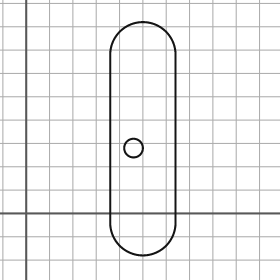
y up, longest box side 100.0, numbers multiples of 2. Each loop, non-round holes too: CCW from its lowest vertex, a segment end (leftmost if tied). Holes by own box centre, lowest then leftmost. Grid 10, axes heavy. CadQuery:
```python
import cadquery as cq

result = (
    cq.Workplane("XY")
    .moveTo(36.0, -4.0)
    .threePointArc((50.0, -18.0), (64.0, -4.0))
    .lineTo(64.0, 68.0)
    .threePointArc((50.0, 82.0), (36.0, 68.0))
    .close()
    .moveTo(46.0, 28.0)
    .circle(4.0)
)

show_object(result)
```